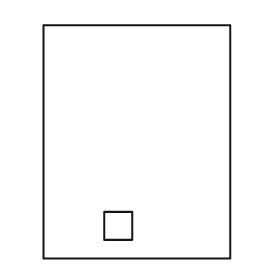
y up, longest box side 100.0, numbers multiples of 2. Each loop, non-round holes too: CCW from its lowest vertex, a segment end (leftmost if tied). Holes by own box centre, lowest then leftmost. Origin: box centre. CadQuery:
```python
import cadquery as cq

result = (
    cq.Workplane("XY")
    .moveTo(-40.0, -50.0)
    .lineTo(40.0, -50.0)
    .lineTo(40.0, 50.0)
    .lineTo(-40.0, 50.0)
    .close()
    .moveTo(-14.0, -42.0)
    .lineTo(-2.0, -42.0)
    .lineTo(-2.0, -30.0)
    .lineTo(-14.0, -30.0)
    .close()
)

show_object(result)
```